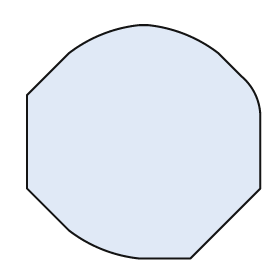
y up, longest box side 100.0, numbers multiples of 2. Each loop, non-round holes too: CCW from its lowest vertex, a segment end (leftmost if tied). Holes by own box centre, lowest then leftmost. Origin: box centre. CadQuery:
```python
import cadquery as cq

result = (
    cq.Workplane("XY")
    .moveTo(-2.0, -50.0)
    .lineTo(20.0, -50.0)
    .lineTo(50.0, -20.0)
    .lineTo(50.0, 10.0)
    .threePointArc((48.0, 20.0), (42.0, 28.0))
    .lineTo(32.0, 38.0)
    .threePointArc((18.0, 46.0), (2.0, 50.0))
    .lineTo(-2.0, 50.0)
    .threePointArc((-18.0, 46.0), (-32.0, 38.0))
    .lineTo(-50.0, 20.0)
    .lineTo(-50.0, -20.0)
    .lineTo(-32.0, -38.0)
    .threePointArc((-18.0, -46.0), (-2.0, -50.0))
    .close()
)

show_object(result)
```